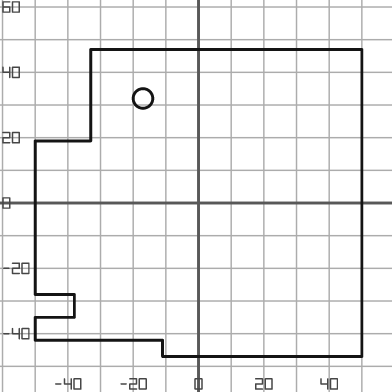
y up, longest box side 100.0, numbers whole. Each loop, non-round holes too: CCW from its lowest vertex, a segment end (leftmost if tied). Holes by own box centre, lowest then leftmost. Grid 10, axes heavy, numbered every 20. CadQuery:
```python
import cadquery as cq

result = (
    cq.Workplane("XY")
    .moveTo(-11.0, -47.0)
    .lineTo(50.0, -47.0)
    .lineTo(50.0, 47.0)
    .lineTo(-33.0, 47.0)
    .lineTo(-33.0, 19.0)
    .lineTo(-50.0, 19.0)
    .lineTo(-50.0, -28.0)
    .lineTo(-38.0, -28.0)
    .lineTo(-38.0, -35.0)
    .lineTo(-50.0, -35.0)
    .lineTo(-50.0, -42.0)
    .lineTo(-11.0, -42.0)
    .close()
    .moveTo(-17.0, 32.0)
    .circle(3.0)
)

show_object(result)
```